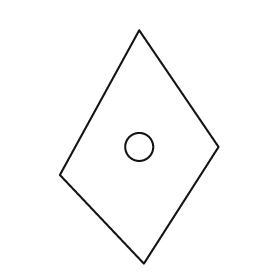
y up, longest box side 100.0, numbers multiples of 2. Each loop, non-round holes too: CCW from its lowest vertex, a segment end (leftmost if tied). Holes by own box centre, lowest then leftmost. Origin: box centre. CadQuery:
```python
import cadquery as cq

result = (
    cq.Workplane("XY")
    .moveTo(2.0, -50.0)
    .lineTo(34.0, 0.0)
    .lineTo(0.0, 50.0)
    .lineTo(-34.0, -12.0)
    .close()
    .moveTo(0.0, 0.0)
    .circle(6.0)
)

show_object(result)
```